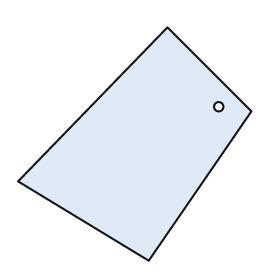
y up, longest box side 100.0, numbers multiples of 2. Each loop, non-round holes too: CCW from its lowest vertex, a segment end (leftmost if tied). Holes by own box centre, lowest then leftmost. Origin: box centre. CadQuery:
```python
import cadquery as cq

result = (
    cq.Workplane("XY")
    .moveTo(6.0, -50.0)
    .lineTo(50.0, 14.0)
    .lineTo(14.0, 50.0)
    .lineTo(-50.0, -16.0)
    .close()
    .moveTo(36.0, 16.0)
    .circle(2.0)
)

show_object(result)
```